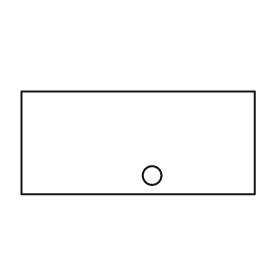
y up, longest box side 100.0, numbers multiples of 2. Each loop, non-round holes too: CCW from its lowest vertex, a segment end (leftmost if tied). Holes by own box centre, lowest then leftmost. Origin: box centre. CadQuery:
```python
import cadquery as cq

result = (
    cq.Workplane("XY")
    .moveTo(-50.0, -22.0)
    .lineTo(50.0, -22.0)
    .lineTo(50.0, 22.0)
    .lineTo(-50.0, 22.0)
    .close()
    .moveTo(6.0, -14.0)
    .circle(4.0)
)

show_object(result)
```